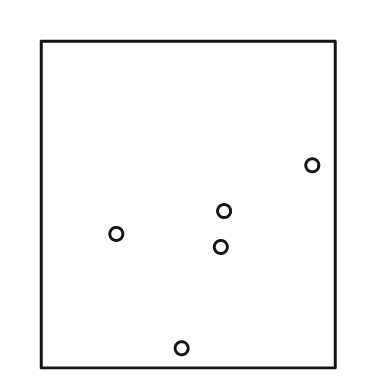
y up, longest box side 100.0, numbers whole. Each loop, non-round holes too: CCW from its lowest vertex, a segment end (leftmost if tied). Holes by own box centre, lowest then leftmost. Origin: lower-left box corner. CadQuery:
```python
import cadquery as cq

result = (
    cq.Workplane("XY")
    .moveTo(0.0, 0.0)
    .lineTo(90.0, 0.0)
    .lineTo(90.0, 100.0)
    .lineTo(0.0, 100.0)
    .close()
    .moveTo(43.0, 6.0)
    .circle(2.0)
    .moveTo(55.0, 37.0)
    .circle(2.0)
    .moveTo(23.0, 41.0)
    .circle(2.0)
    .moveTo(56.0, 48.0)
    .circle(2.0)
    .moveTo(83.0, 62.0)
    .circle(2.0)
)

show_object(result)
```